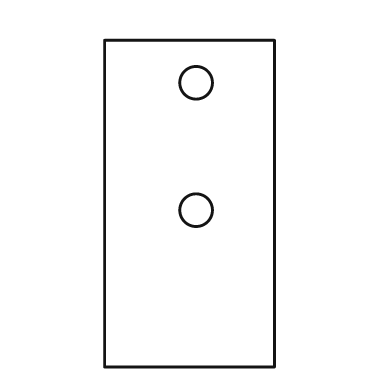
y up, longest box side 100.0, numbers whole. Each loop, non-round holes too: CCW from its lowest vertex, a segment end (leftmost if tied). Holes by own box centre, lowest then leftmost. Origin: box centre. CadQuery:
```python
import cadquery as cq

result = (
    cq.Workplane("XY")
    .moveTo(-26.0, -50.0)
    .lineTo(26.0, -50.0)
    .lineTo(26.0, 50.0)
    .lineTo(-26.0, 50.0)
    .close()
    .moveTo(2.0, -2.0)
    .circle(5.0)
    .moveTo(2.0, 37.0)
    .circle(5.0)
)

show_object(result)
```